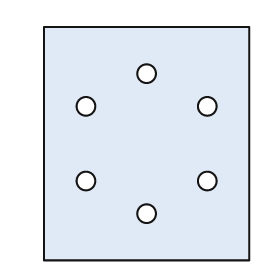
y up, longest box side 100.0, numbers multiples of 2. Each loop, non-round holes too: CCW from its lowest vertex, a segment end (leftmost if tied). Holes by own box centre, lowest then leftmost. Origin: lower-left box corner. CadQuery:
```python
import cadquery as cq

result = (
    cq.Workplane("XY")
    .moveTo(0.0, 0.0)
    .lineTo(88.0, 0.0)
    .lineTo(88.0, 100.0)
    .lineTo(0.0, 100.0)
    .close()
    .moveTo(44.0, 20.0)
    .circle(4.0)
    .moveTo(18.0, 34.0)
    .circle(4.0)
    .moveTo(70.0, 34.0)
    .circle(4.0)
    .moveTo(18.0, 66.0)
    .circle(4.0)
    .moveTo(70.0, 66.0)
    .circle(4.0)
    .moveTo(44.0, 80.0)
    .circle(4.0)
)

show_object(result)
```